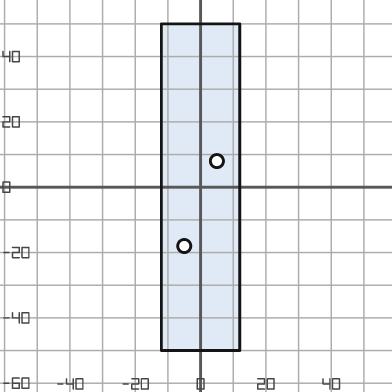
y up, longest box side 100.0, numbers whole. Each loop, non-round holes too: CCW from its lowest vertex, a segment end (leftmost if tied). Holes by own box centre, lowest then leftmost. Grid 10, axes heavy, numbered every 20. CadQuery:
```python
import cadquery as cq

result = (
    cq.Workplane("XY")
    .moveTo(-12.0, -50.0)
    .lineTo(12.0, -50.0)
    .lineTo(12.0, 50.0)
    .lineTo(-12.0, 50.0)
    .close()
    .moveTo(-5.0, -18.0)
    .circle(2.0)
    .moveTo(5.0, 8.0)
    .circle(2.0)
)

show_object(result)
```